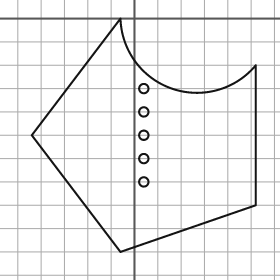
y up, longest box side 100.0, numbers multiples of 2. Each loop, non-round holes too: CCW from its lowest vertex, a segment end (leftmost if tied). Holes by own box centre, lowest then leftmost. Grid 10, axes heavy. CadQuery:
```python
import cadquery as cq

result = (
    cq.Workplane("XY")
    .moveTo(-6.0, -100.0)
    .lineTo(52.0, -80.0)
    .lineTo(52.0, -20.0)
    .threePointArc((16.0, -30.0), (-6.0, 0.0))
    .lineTo(-44.0, -50.0)
    .close()
    .moveTo(4.0, -70.0)
    .circle(2.0)
    .moveTo(4.0, -60.0)
    .circle(2.0)
    .moveTo(4.0, -50.0)
    .circle(2.0)
    .moveTo(4.0, -40.0)
    .circle(2.0)
    .moveTo(4.0, -30.0)
    .circle(2.0)
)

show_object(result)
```